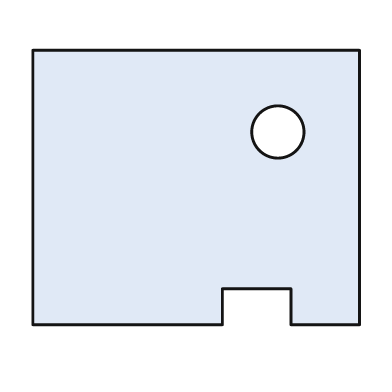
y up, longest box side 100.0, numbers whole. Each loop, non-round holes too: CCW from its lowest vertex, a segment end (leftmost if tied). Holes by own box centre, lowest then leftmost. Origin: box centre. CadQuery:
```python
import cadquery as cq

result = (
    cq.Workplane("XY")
    .moveTo(-50.0, -42.0)
    .lineTo(8.0, -42.0)
    .lineTo(8.0, -31.0)
    .lineTo(29.0, -31.0)
    .lineTo(29.0, -42.0)
    .lineTo(50.0, -42.0)
    .lineTo(50.0, 42.0)
    .lineTo(-50.0, 42.0)
    .close()
    .moveTo(25.0, 17.0)
    .circle(8.0)
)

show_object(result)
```